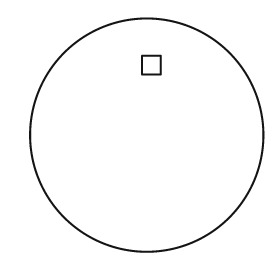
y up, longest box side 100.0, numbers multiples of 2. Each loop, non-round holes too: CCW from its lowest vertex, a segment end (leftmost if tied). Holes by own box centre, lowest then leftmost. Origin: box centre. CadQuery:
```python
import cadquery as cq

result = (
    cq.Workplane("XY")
    .moveTo(0.0, 0.0)
    .circle(50.0)
    .moveTo(-2.0, 26.0)
    .lineTo(6.0, 26.0)
    .lineTo(6.0, 34.0)
    .lineTo(-2.0, 34.0)
    .close()
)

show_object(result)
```